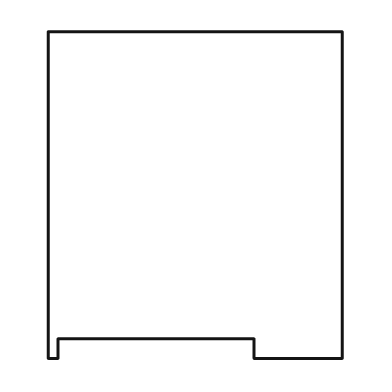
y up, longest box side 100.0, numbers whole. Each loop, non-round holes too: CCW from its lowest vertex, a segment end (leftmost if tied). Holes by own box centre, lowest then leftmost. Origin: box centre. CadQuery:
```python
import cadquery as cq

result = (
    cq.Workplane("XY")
    .moveTo(-45.0, -50.0)
    .lineTo(-42.0, -50.0)
    .lineTo(-42.0, -44.0)
    .lineTo(18.0, -44.0)
    .lineTo(18.0, -50.0)
    .lineTo(45.0, -50.0)
    .lineTo(45.0, 50.0)
    .lineTo(-45.0, 50.0)
    .close()
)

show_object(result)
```